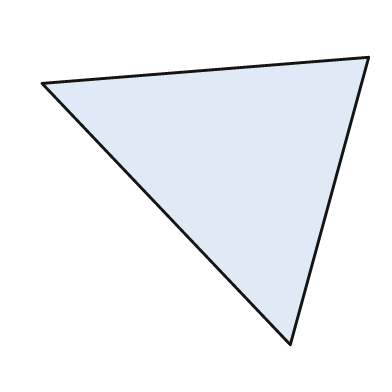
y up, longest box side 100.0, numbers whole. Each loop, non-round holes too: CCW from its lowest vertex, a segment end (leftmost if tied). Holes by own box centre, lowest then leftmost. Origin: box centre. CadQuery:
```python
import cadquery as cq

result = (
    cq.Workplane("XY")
    .moveTo(26.0, -44.0)
    .lineTo(50.0, 44.0)
    .lineTo(-50.0, 36.0)
    .close()
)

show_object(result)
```